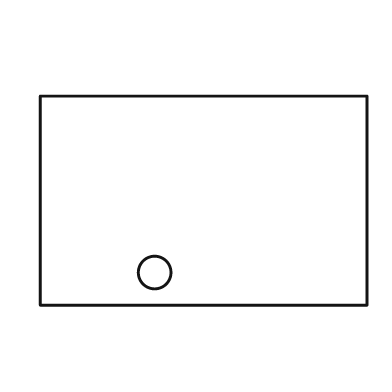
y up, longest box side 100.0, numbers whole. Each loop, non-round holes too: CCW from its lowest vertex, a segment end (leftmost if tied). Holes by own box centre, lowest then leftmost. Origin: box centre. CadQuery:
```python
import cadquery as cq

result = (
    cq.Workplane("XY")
    .moveTo(-50.0, -32.0)
    .lineTo(50.0, -32.0)
    .lineTo(50.0, 32.0)
    .lineTo(-50.0, 32.0)
    .close()
    .moveTo(-15.0, -22.0)
    .circle(5.0)
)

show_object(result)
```